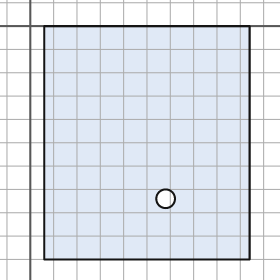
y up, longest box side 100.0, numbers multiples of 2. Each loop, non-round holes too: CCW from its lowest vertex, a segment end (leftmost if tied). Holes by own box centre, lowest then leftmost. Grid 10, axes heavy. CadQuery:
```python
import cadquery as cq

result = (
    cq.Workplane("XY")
    .moveTo(6.0, -100.0)
    .lineTo(94.0, -100.0)
    .lineTo(94.0, 0.0)
    .lineTo(6.0, 0.0)
    .close()
    .moveTo(58.0, -74.0)
    .circle(4.0)
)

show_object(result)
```